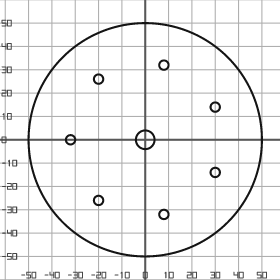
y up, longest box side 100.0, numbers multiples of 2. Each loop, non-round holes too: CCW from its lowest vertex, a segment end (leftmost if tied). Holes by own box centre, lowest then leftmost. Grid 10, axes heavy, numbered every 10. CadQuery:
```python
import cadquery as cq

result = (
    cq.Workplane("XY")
    .moveTo(0.0, 0.0)
    .circle(50.0)
    .moveTo(8.0, -32.0)
    .circle(2.0)
    .moveTo(-20.0, -26.0)
    .circle(2.0)
    .moveTo(30.0, -14.0)
    .circle(2.0)
    .moveTo(-32.0, 0.0)
    .circle(2.0)
    .moveTo(0.0, 0.0)
    .circle(4.0)
    .moveTo(30.0, 14.0)
    .circle(2.0)
    .moveTo(-20.0, 26.0)
    .circle(2.0)
    .moveTo(8.0, 32.0)
    .circle(2.0)
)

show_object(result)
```